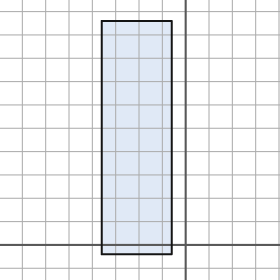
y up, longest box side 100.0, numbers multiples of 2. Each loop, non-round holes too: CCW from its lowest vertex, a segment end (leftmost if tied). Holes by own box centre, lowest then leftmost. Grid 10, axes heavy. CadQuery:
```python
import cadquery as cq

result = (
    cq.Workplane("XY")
    .moveTo(-36.0, -4.0)
    .lineTo(-6.0, -4.0)
    .lineTo(-6.0, 96.0)
    .lineTo(-36.0, 96.0)
    .close()
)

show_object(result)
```